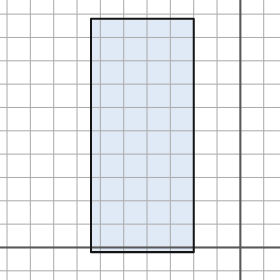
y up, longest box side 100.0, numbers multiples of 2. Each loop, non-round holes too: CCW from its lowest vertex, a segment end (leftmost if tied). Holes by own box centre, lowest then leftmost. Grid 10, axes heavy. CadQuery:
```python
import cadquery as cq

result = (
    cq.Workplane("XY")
    .moveTo(-64.0, -2.0)
    .lineTo(-20.0, -2.0)
    .lineTo(-20.0, 98.0)
    .lineTo(-64.0, 98.0)
    .close()
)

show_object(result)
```